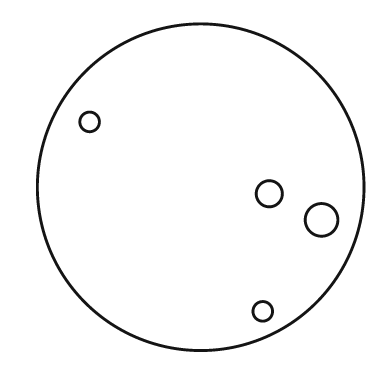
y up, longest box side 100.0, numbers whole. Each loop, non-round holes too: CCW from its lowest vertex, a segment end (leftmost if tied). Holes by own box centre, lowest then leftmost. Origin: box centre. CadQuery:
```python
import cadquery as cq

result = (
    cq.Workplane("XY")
    .moveTo(0.0, 0.0)
    .circle(50.0)
    .moveTo(19.0, -38.0)
    .circle(3.0)
    .moveTo(37.0, -10.0)
    .circle(5.0)
    .moveTo(21.0, -2.0)
    .circle(4.0)
    .moveTo(-34.0, 20.0)
    .circle(3.0)
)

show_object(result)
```